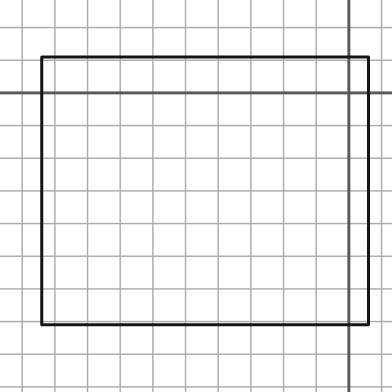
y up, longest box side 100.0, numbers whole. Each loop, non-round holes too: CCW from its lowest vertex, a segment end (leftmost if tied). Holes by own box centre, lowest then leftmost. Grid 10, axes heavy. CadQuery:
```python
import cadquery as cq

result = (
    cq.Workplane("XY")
    .moveTo(-94.0, -71.0)
    .lineTo(6.0, -71.0)
    .lineTo(6.0, 11.0)
    .lineTo(-94.0, 11.0)
    .close()
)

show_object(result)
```